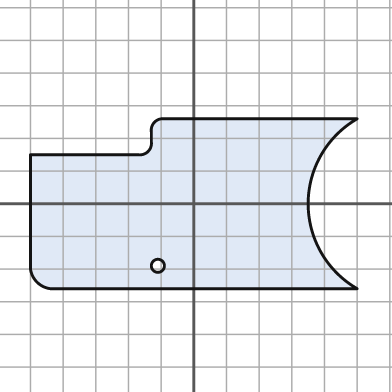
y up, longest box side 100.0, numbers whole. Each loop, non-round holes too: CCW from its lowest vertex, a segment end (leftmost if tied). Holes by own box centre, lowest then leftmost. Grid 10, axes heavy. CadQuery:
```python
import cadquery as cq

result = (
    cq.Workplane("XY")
    .moveTo(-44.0, -26.0)
    .lineTo(50.0, -26.0)
    .threePointArc((35.0, 0.0), (50.0, 26.0))
    .lineTo(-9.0, 26.0)
    .threePointArc((-12.0, 25.0), (-13.0, 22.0))
    .lineTo(-13.0, 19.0)
    .threePointArc((-14.0, 16.0), (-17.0, 15.0))
    .lineTo(-50.0, 15.0)
    .lineTo(-50.0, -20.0)
    .threePointArc((-48.0, -24.0), (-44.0, -26.0))
    .close()
    .moveTo(-11.0, -19.0)
    .circle(2.0)
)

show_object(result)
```